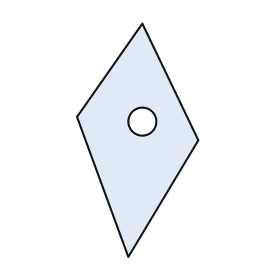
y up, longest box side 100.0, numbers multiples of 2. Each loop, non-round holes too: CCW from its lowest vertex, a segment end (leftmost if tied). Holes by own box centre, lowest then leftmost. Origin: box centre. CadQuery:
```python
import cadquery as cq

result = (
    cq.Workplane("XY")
    .moveTo(-4.0, -50.0)
    .lineTo(26.0, 0.0)
    .lineTo(2.0, 50.0)
    .lineTo(-26.0, 10.0)
    .close()
    .moveTo(2.0, 8.0)
    .circle(6.0)
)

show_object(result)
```